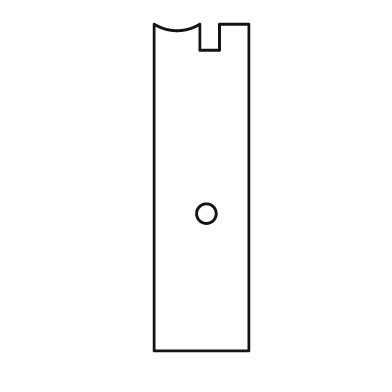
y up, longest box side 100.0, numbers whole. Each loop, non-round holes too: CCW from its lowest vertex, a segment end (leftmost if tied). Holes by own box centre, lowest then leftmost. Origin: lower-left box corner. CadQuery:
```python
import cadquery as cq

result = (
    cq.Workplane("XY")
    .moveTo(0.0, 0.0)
    .lineTo(29.0, 0.0)
    .lineTo(29.0, 100.0)
    .lineTo(20.0, 100.0)
    .lineTo(20.0, 92.0)
    .lineTo(14.0, 92.0)
    .lineTo(14.0, 100.0)
    .threePointArc((7.0, 98.0), (0.0, 100.0))
    .close()
    .moveTo(16.0, 42.0)
    .circle(3.0)
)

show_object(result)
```